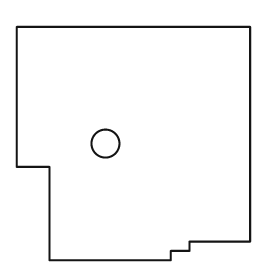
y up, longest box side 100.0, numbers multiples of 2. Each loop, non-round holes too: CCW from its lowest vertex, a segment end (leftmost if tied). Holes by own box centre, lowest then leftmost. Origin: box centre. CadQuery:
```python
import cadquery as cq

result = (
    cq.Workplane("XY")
    .moveTo(-36.0, -50.0)
    .lineTo(16.0, -50.0)
    .lineTo(16.0, -46.0)
    .lineTo(24.0, -46.0)
    .lineTo(24.0, -42.0)
    .lineTo(50.0, -42.0)
    .lineTo(50.0, 50.0)
    .lineTo(-50.0, 50.0)
    .lineTo(-50.0, -10.0)
    .lineTo(-36.0, -10.0)
    .close()
    .moveTo(-12.0, 0.0)
    .circle(6.0)
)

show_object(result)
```